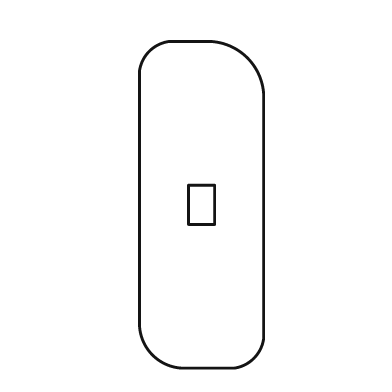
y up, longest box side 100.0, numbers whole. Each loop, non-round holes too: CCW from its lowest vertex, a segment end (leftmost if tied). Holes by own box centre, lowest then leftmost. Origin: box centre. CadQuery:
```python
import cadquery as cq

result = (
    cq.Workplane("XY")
    .moveTo(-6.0, -50.0)
    .lineTo(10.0, -50.0)
    .threePointArc((16.0, -47.0), (19.0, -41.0))
    .lineTo(19.0, 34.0)
    .threePointArc((14.0, 45.0), (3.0, 50.0))
    .lineTo(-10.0, 50.0)
    .threePointArc((-16.0, 47.0), (-19.0, 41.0))
    .lineTo(-19.0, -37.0)
    .threePointArc((-15.0, -46.0), (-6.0, -50.0))
    .close()
    .moveTo(-4.0, -6.0)
    .lineTo(4.0, -6.0)
    .lineTo(4.0, 6.0)
    .lineTo(-4.0, 6.0)
    .close()
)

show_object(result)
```